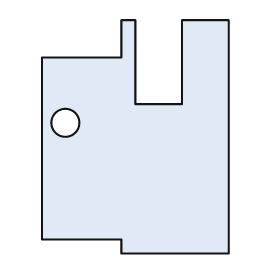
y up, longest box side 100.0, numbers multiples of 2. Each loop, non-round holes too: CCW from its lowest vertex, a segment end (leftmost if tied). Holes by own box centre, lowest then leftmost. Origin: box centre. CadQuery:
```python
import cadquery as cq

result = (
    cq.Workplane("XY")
    .moveTo(-6.0, -50.0)
    .lineTo(40.0, -50.0)
    .lineTo(40.0, 50.0)
    .lineTo(20.0, 50.0)
    .lineTo(20.0, 14.0)
    .lineTo(0.0, 14.0)
    .lineTo(0.0, 50.0)
    .lineTo(-6.0, 50.0)
    .lineTo(-6.0, 34.0)
    .lineTo(-40.0, 34.0)
    .lineTo(-40.0, -44.0)
    .lineTo(-6.0, -44.0)
    .close()
    .moveTo(-30.0, 6.0)
    .circle(6.0)
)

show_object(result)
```